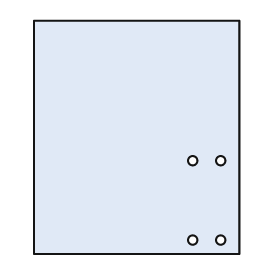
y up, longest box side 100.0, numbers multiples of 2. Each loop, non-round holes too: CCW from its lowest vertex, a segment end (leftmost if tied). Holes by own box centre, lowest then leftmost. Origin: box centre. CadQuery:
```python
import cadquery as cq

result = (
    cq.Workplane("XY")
    .moveTo(-44.0, -50.0)
    .lineTo(44.0, -50.0)
    .lineTo(44.0, 50.0)
    .lineTo(-44.0, 50.0)
    .close()
    .moveTo(24.0, -44.0)
    .circle(2.0)
    .moveTo(36.0, -44.0)
    .circle(2.0)
    .moveTo(24.0, -10.0)
    .circle(2.0)
    .moveTo(36.0, -10.0)
    .circle(2.0)
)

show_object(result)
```